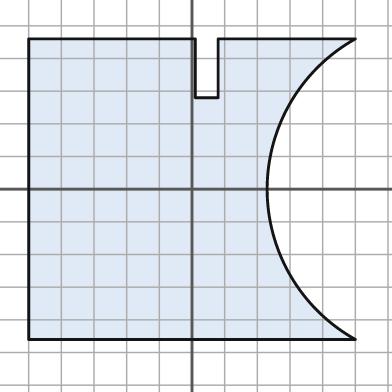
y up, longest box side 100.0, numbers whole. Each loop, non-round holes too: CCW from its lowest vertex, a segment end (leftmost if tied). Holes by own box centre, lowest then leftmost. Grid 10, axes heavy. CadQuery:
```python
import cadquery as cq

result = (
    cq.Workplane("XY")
    .moveTo(-50.0, -46.0)
    .lineTo(50.0, -46.0)
    .threePointArc((23.0, 0.0), (50.0, 46.0))
    .lineTo(8.0, 46.0)
    .lineTo(8.0, 28.0)
    .lineTo(1.0, 28.0)
    .lineTo(1.0, 46.0)
    .lineTo(-50.0, 46.0)
    .close()
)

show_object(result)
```